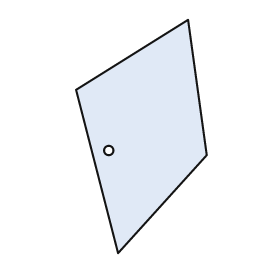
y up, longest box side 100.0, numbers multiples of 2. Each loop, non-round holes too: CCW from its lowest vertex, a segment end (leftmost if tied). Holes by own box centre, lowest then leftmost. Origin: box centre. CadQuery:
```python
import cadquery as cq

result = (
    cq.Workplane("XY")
    .moveTo(-10.0, -50.0)
    .lineTo(28.0, -8.0)
    .lineTo(20.0, 50.0)
    .lineTo(-28.0, 20.0)
    .close()
    .moveTo(-14.0, -6.0)
    .circle(2.0)
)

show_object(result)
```